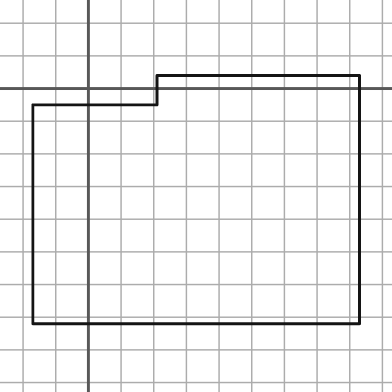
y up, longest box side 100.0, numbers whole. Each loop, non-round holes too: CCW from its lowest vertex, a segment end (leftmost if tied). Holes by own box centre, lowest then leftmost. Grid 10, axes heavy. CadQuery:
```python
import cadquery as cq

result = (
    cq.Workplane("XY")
    .moveTo(-17.0, -72.0)
    .lineTo(83.0, -72.0)
    .lineTo(83.0, 4.0)
    .lineTo(21.0, 4.0)
    .lineTo(21.0, -5.0)
    .lineTo(-17.0, -5.0)
    .close()
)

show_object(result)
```